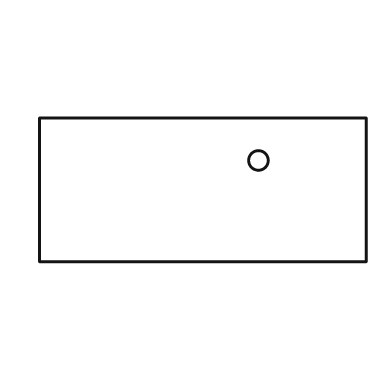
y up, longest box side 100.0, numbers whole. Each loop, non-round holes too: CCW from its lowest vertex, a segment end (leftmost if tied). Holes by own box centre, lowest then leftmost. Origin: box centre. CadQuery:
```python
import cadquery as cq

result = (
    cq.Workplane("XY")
    .moveTo(-50.0, -22.0)
    .lineTo(50.0, -22.0)
    .lineTo(50.0, 22.0)
    .lineTo(-50.0, 22.0)
    .close()
    .moveTo(17.0, 9.0)
    .circle(3.0)
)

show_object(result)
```